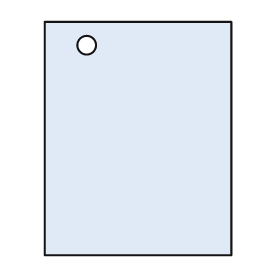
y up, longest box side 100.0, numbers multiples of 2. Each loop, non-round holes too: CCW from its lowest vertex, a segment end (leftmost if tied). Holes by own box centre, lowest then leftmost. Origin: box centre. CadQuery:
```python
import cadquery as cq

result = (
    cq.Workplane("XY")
    .moveTo(-40.0, -50.0)
    .lineTo(40.0, -50.0)
    .lineTo(40.0, 50.0)
    .lineTo(-40.0, 50.0)
    .close()
    .moveTo(-22.0, 40.0)
    .circle(4.0)
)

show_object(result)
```